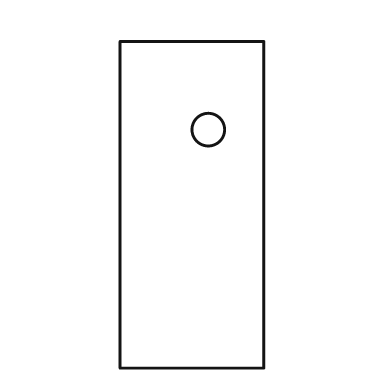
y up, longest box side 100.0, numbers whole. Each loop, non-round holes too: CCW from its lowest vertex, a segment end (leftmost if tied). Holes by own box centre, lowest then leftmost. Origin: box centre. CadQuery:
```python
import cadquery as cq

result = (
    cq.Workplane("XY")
    .moveTo(-22.0, -50.0)
    .lineTo(22.0, -50.0)
    .lineTo(22.0, 50.0)
    .lineTo(-22.0, 50.0)
    .close()
    .moveTo(5.0, 23.0)
    .circle(5.0)
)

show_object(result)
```